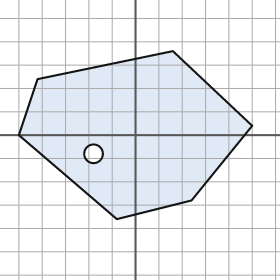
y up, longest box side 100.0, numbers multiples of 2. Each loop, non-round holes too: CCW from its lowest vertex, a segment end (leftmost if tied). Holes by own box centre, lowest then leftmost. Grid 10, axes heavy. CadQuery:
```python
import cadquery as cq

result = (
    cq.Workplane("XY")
    .moveTo(-8.0, -36.0)
    .lineTo(24.0, -28.0)
    .lineTo(50.0, 4.0)
    .lineTo(16.0, 36.0)
    .lineTo(-42.0, 24.0)
    .lineTo(-50.0, 0.0)
    .close()
    .moveTo(-18.0, -8.0)
    .circle(4.0)
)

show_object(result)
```